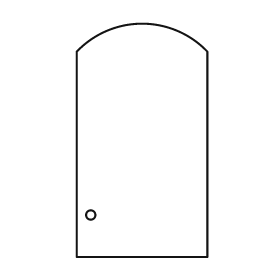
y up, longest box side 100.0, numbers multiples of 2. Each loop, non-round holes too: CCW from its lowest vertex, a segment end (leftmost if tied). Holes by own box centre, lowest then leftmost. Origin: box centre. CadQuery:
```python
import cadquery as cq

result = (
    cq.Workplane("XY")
    .moveTo(-28.0, -50.0)
    .lineTo(28.0, -50.0)
    .lineTo(28.0, 38.0)
    .threePointArc((0.0, 50.0), (-28.0, 38.0))
    .close()
    .moveTo(-22.0, -32.0)
    .circle(2.0)
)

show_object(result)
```